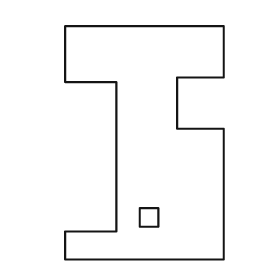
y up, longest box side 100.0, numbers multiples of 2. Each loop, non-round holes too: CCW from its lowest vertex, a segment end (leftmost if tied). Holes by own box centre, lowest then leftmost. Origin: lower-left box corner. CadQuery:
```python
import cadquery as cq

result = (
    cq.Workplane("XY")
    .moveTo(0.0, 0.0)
    .lineTo(68.0, 0.0)
    .lineTo(68.0, 56.0)
    .lineTo(48.0, 56.0)
    .lineTo(48.0, 78.0)
    .lineTo(68.0, 78.0)
    .lineTo(68.0, 100.0)
    .lineTo(0.0, 100.0)
    .lineTo(0.0, 76.0)
    .lineTo(22.0, 76.0)
    .lineTo(22.0, 12.0)
    .lineTo(0.0, 12.0)
    .close()
    .moveTo(32.0, 14.0)
    .lineTo(40.0, 14.0)
    .lineTo(40.0, 22.0)
    .lineTo(32.0, 22.0)
    .close()
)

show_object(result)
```